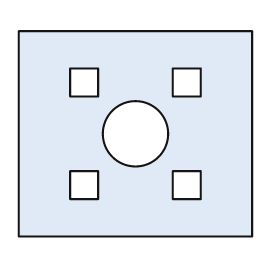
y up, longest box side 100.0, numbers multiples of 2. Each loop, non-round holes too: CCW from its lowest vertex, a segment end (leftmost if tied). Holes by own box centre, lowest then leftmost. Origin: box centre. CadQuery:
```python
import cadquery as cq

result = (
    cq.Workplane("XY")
    .moveTo(-50.0, -44.0)
    .lineTo(50.0, -44.0)
    .lineTo(50.0, 44.0)
    .lineTo(-50.0, 44.0)
    .close()
    .moveTo(-28.0, -28.0)
    .lineTo(-16.0, -28.0)
    .lineTo(-16.0, -16.0)
    .lineTo(-28.0, -16.0)
    .close()
    .moveTo(16.0, -28.0)
    .lineTo(28.0, -28.0)
    .lineTo(28.0, -16.0)
    .lineTo(16.0, -16.0)
    .close()
    .moveTo(0.0, 0.0)
    .circle(14.0)
    .moveTo(-28.0, 16.0)
    .lineTo(-16.0, 16.0)
    .lineTo(-16.0, 28.0)
    .lineTo(-28.0, 28.0)
    .close()
    .moveTo(16.0, 16.0)
    .lineTo(28.0, 16.0)
    .lineTo(28.0, 28.0)
    .lineTo(16.0, 28.0)
    .close()
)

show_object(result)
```